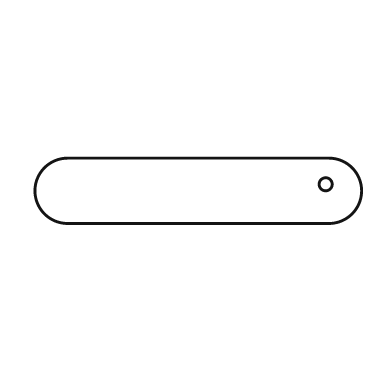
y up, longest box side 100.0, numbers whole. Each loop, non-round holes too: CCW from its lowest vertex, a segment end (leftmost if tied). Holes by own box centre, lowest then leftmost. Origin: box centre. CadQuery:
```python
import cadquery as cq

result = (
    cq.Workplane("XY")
    .moveTo(-40.0, -10.0)
    .lineTo(40.0, -10.0)
    .threePointArc((50.0, 0.0), (40.0, 10.0))
    .lineTo(-40.0, 10.0)
    .threePointArc((-50.0, 0.0), (-40.0, -10.0))
    .close()
    .moveTo(39.0, 2.0)
    .circle(2.0)
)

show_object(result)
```